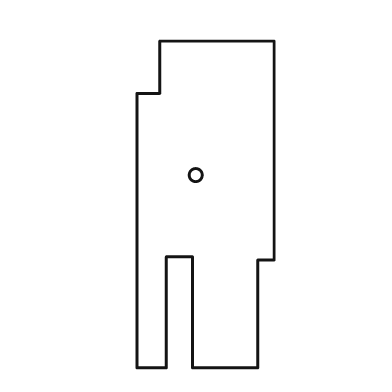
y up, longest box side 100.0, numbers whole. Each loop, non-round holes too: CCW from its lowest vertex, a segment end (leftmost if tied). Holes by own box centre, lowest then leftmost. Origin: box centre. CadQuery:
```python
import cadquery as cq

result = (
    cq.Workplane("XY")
    .moveTo(-21.0, -50.0)
    .lineTo(-12.0, -50.0)
    .lineTo(-12.0, -16.0)
    .lineTo(-4.0, -16.0)
    .lineTo(-4.0, -50.0)
    .lineTo(16.0, -50.0)
    .lineTo(16.0, -17.0)
    .lineTo(21.0, -17.0)
    .lineTo(21.0, 50.0)
    .lineTo(-14.0, 50.0)
    .lineTo(-14.0, 34.0)
    .lineTo(-21.0, 34.0)
    .close()
    .moveTo(-3.0, 9.0)
    .circle(2.0)
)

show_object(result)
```